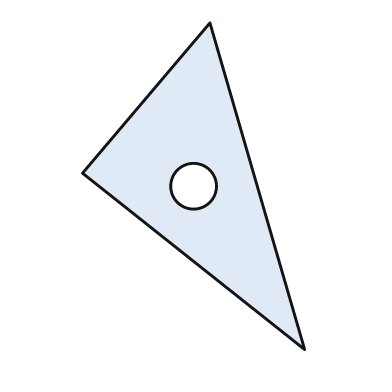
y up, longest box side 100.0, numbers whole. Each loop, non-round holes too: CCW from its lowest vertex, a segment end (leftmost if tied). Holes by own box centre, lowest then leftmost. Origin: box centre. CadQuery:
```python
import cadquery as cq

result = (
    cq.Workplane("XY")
    .moveTo(34.0, -50.0)
    .lineTo(5.0, 50.0)
    .lineTo(-34.0, 4.0)
    .close()
    .moveTo(0.0, 0.0)
    .circle(7.0)
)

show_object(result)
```